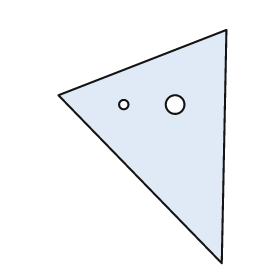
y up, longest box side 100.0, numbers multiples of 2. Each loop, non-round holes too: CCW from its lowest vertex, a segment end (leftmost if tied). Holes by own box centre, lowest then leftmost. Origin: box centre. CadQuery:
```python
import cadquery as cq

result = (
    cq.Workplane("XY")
    .moveTo(34.0, -50.0)
    .lineTo(36.0, 50.0)
    .lineTo(-36.0, 22.0)
    .close()
    .moveTo(-8.0, 18.0)
    .circle(2.0)
    .moveTo(14.0, 18.0)
    .circle(4.0)
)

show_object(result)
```